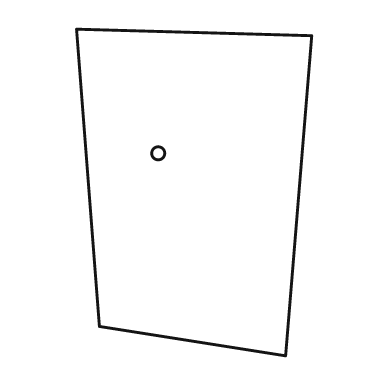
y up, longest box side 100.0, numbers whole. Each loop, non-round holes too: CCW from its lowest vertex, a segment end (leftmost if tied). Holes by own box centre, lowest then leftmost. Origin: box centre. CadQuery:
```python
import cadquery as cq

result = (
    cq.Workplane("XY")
    .moveTo(28.0, -50.0)
    .lineTo(36.0, 48.0)
    .lineTo(-36.0, 50.0)
    .lineTo(-29.0, -41.0)
    .close()
    .moveTo(-11.0, 12.0)
    .circle(2.0)
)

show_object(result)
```